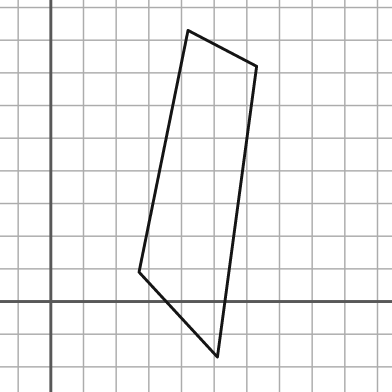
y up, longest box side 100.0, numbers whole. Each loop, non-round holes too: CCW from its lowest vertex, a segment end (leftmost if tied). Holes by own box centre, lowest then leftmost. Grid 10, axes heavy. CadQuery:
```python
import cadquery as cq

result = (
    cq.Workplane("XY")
    .moveTo(51.0, -17.0)
    .lineTo(63.0, 72.0)
    .lineTo(42.0, 83.0)
    .lineTo(27.0, 9.0)
    .close()
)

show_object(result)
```